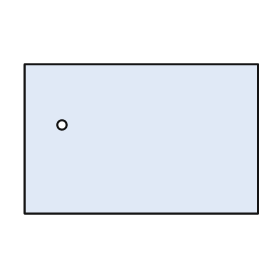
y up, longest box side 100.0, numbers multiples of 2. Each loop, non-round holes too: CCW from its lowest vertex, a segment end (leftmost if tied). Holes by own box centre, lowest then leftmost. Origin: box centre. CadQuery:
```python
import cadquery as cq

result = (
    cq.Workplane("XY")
    .moveTo(-50.0, -32.0)
    .lineTo(50.0, -32.0)
    .lineTo(50.0, 32.0)
    .lineTo(-50.0, 32.0)
    .close()
    .moveTo(-34.0, 6.0)
    .circle(2.0)
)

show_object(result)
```